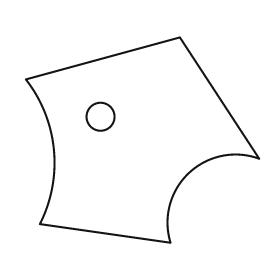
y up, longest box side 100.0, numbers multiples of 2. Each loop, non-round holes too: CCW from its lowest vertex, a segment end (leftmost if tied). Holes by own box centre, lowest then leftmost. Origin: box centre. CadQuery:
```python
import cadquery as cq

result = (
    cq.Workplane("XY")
    .moveTo(12.0, -44.0)
    .threePointArc((20.0, -14.0), (50.0, -8.0))
    .lineTo(16.0, 44.0)
    .lineTo(-50.0, 26.0)
    .threePointArc((-38.0, -4.0), (-44.0, -36.0))
    .close()
    .moveTo(-18.0, 10.0)
    .circle(6.0)
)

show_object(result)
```